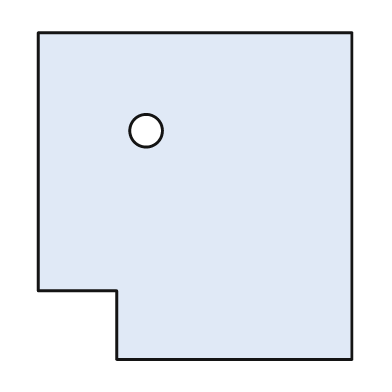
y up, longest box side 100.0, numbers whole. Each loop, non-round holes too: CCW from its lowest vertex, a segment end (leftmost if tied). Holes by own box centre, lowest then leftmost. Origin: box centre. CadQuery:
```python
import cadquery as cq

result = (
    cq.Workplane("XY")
    .moveTo(-24.0, -50.0)
    .lineTo(48.0, -50.0)
    .lineTo(48.0, 50.0)
    .lineTo(-48.0, 50.0)
    .lineTo(-48.0, -29.0)
    .lineTo(-24.0, -29.0)
    .close()
    .moveTo(-15.0, 20.0)
    .circle(5.0)
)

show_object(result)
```